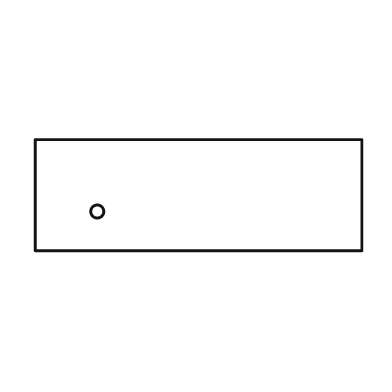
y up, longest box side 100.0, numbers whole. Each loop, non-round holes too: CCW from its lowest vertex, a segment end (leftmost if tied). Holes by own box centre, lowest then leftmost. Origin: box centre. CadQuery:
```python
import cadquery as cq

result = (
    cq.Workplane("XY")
    .moveTo(-50.0, -17.0)
    .lineTo(50.0, -17.0)
    .lineTo(50.0, 17.0)
    .lineTo(-50.0, 17.0)
    .close()
    .moveTo(-31.0, -5.0)
    .circle(2.0)
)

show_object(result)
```